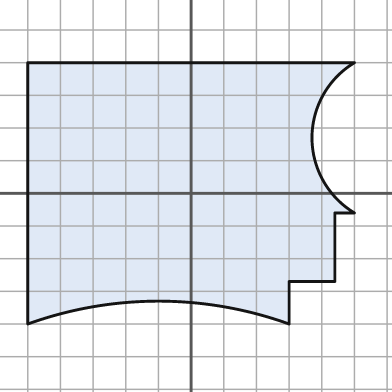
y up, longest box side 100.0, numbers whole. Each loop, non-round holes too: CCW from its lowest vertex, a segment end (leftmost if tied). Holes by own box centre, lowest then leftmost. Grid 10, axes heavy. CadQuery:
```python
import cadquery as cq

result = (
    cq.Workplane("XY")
    .moveTo(-50.0, -40.0)
    .threePointArc((-10.0, -33.0), (30.0, -40.0))
    .lineTo(30.0, -27.0)
    .lineTo(44.0, -27.0)
    .lineTo(44.0, -6.0)
    .lineTo(50.0, -6.0)
    .threePointArc((37.0, 17.0), (50.0, 40.0))
    .lineTo(-50.0, 40.0)
    .close()
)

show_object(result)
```